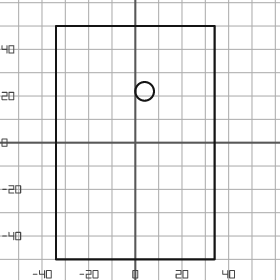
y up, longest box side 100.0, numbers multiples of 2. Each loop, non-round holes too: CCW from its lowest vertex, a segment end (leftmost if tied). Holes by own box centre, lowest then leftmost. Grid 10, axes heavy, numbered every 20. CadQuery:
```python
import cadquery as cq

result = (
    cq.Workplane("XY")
    .moveTo(-34.0, -50.0)
    .lineTo(34.0, -50.0)
    .lineTo(34.0, 50.0)
    .lineTo(-34.0, 50.0)
    .close()
    .moveTo(4.0, 22.0)
    .circle(4.0)
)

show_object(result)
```